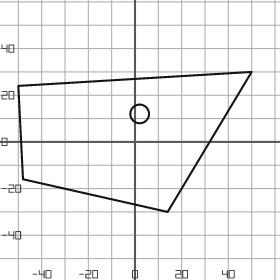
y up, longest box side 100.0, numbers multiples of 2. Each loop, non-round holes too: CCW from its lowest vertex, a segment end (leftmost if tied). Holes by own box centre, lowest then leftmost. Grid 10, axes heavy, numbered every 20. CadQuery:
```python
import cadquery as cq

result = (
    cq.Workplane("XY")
    .moveTo(14.0, -30.0)
    .lineTo(50.0, 30.0)
    .lineTo(-50.0, 24.0)
    .lineTo(-48.0, -16.0)
    .close()
    .moveTo(2.0, 12.0)
    .circle(4.0)
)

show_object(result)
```